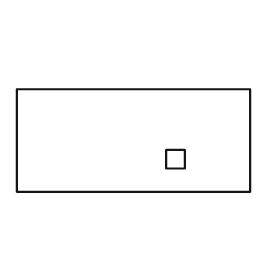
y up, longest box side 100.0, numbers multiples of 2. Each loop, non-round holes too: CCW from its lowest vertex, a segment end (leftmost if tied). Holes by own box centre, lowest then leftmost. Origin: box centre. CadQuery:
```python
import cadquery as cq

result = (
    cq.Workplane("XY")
    .moveTo(-50.0, -22.0)
    .lineTo(50.0, -22.0)
    .lineTo(50.0, 22.0)
    .lineTo(-50.0, 22.0)
    .close()
    .moveTo(14.0, -12.0)
    .lineTo(22.0, -12.0)
    .lineTo(22.0, -4.0)
    .lineTo(14.0, -4.0)
    .close()
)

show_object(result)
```